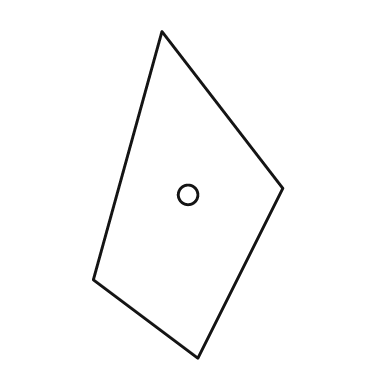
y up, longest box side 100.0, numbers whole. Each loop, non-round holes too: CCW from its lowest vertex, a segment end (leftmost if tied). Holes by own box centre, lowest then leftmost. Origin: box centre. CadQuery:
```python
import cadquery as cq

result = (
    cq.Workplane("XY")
    .moveTo(3.0, -50.0)
    .lineTo(29.0, 2.0)
    .lineTo(-8.0, 50.0)
    .lineTo(-29.0, -26.0)
    .close()
    .moveTo(0.0, 0.0)
    .circle(3.0)
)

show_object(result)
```